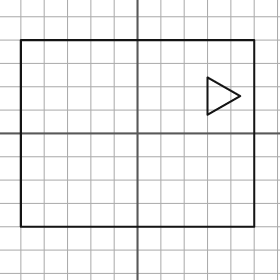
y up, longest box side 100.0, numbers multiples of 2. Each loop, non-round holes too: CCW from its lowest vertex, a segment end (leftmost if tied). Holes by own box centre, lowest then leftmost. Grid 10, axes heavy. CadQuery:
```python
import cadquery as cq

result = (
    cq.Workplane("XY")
    .moveTo(-50.0, -40.0)
    .lineTo(50.0, -40.0)
    .lineTo(50.0, 40.0)
    .lineTo(-50.0, 40.0)
    .close()
    .moveTo(30.0, 8.0)
    .lineTo(44.0, 16.0)
    .lineTo(30.0, 24.0)
    .close()
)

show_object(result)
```